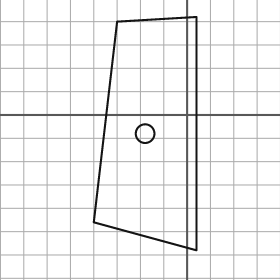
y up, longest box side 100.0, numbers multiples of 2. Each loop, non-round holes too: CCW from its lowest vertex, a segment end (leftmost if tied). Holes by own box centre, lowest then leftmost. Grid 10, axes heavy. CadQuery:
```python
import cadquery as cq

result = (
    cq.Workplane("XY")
    .moveTo(4.0, -58.0)
    .lineTo(4.0, 42.0)
    .lineTo(-30.0, 40.0)
    .lineTo(-40.0, -46.0)
    .close()
    .moveTo(-18.0, -8.0)
    .circle(4.0)
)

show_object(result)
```